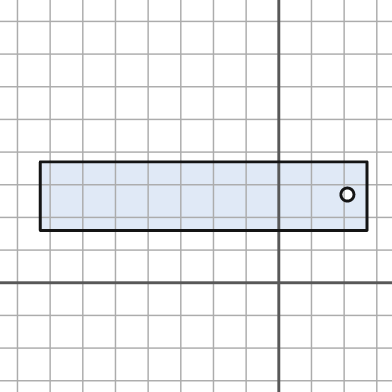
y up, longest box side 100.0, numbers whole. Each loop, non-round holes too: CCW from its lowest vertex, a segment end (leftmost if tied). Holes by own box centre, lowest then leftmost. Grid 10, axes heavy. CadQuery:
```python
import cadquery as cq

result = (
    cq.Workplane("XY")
    .moveTo(-73.0, 16.0)
    .lineTo(27.0, 16.0)
    .lineTo(27.0, 37.0)
    .lineTo(-73.0, 37.0)
    .close()
    .moveTo(21.0, 27.0)
    .circle(2.0)
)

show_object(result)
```